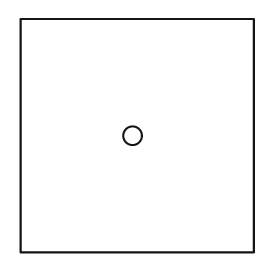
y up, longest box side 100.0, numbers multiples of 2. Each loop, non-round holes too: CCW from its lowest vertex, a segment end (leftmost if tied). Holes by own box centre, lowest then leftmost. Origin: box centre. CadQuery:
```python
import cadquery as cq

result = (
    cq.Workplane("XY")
    .moveTo(-50.0, -50.0)
    .lineTo(50.0, -50.0)
    .lineTo(50.0, 50.0)
    .lineTo(-50.0, 50.0)
    .close()
    .moveTo(-2.0, 0.0)
    .circle(4.0)
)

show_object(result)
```